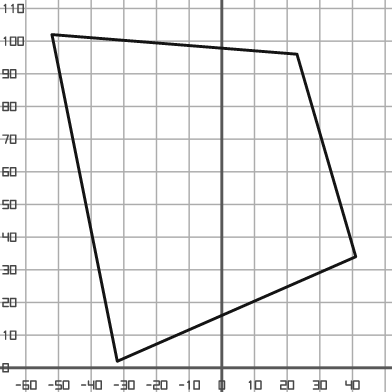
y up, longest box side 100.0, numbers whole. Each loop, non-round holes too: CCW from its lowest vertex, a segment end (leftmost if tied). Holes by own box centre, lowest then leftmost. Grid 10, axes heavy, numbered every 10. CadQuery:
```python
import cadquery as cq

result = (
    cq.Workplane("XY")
    .moveTo(-32.0, 2.0)
    .lineTo(41.0, 34.0)
    .lineTo(23.0, 96.0)
    .lineTo(-52.0, 102.0)
    .close()
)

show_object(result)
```